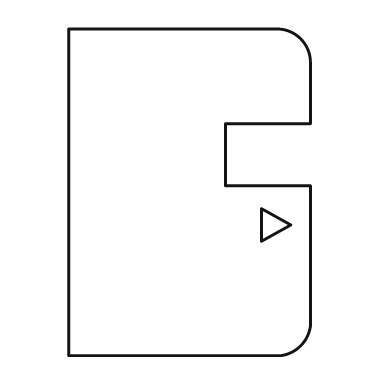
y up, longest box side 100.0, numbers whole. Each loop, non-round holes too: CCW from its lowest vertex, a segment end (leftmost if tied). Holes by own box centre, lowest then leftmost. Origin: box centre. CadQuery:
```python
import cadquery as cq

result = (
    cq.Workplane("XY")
    .moveTo(-37.0, -50.0)
    .lineTo(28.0, -50.0)
    .threePointArc((34.0, -47.0), (37.0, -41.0))
    .lineTo(37.0, 2.0)
    .lineTo(11.0, 2.0)
    .lineTo(11.0, 21.0)
    .lineTo(37.0, 21.0)
    .lineTo(37.0, 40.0)
    .threePointArc((34.0, 47.0), (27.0, 50.0))
    .lineTo(-37.0, 50.0)
    .close()
    .moveTo(22.0, -15.0)
    .lineTo(31.0, -10.0)
    .lineTo(22.0, -5.0)
    .close()
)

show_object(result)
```